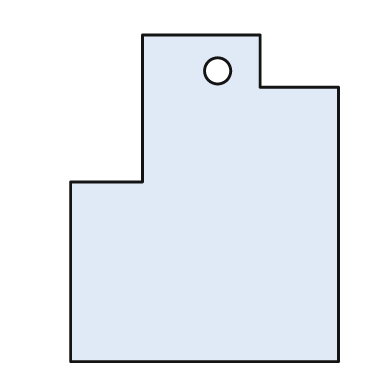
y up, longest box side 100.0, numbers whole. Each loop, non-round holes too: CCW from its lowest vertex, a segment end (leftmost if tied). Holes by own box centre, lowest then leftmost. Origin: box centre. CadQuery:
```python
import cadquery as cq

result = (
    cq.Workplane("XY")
    .moveTo(-41.0, -50.0)
    .lineTo(41.0, -50.0)
    .lineTo(41.0, 34.0)
    .lineTo(17.0, 34.0)
    .lineTo(17.0, 50.0)
    .lineTo(-19.0, 50.0)
    .lineTo(-19.0, 5.0)
    .lineTo(-41.0, 5.0)
    .close()
    .moveTo(4.0, 39.0)
    .circle(4.0)
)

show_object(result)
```